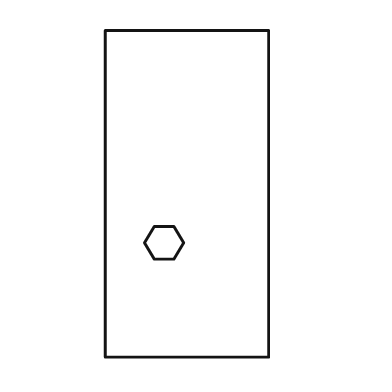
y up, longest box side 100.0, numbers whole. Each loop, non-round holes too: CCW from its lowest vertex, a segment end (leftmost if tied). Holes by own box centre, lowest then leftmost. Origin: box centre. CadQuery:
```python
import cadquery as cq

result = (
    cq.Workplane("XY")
    .moveTo(-25.0, -50.0)
    .lineTo(25.0, -50.0)
    .lineTo(25.0, 50.0)
    .lineTo(-25.0, 50.0)
    .close()
    .moveTo(-10.0, -20.0)
    .lineTo(-4.0, -20.0)
    .lineTo(-1.0, -15.0)
    .lineTo(-4.0, -10.0)
    .lineTo(-10.0, -10.0)
    .lineTo(-13.0, -15.0)
    .close()
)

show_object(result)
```